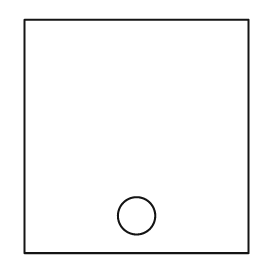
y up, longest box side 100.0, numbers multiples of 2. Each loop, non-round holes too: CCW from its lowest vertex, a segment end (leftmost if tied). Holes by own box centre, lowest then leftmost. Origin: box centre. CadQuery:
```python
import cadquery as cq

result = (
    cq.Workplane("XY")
    .moveTo(-48.0, -50.0)
    .lineTo(48.0, -50.0)
    .lineTo(48.0, 50.0)
    .lineTo(-48.0, 50.0)
    .close()
    .moveTo(0.0, -34.0)
    .circle(8.0)
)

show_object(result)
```